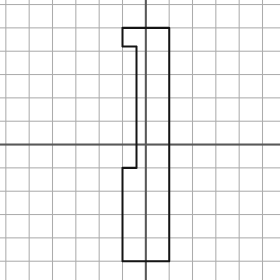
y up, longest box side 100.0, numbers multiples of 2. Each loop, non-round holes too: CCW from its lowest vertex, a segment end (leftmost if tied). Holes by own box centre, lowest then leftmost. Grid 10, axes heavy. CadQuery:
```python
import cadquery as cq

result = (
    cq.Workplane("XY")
    .moveTo(-10.0, -50.0)
    .lineTo(10.0, -50.0)
    .lineTo(10.0, 50.0)
    .lineTo(-10.0, 50.0)
    .lineTo(-10.0, 42.0)
    .lineTo(-4.0, 42.0)
    .lineTo(-4.0, -10.0)
    .lineTo(-10.0, -10.0)
    .close()
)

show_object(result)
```